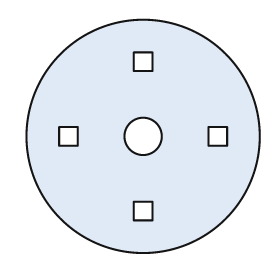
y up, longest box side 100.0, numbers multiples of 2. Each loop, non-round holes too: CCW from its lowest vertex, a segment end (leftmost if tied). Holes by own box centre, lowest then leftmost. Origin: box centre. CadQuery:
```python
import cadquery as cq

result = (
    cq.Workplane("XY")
    .moveTo(0.0, 0.0)
    .circle(50.0)
    .moveTo(-4.0, -36.0)
    .lineTo(4.0, -36.0)
    .lineTo(4.0, -28.0)
    .lineTo(-4.0, -28.0)
    .close()
    .moveTo(-36.0, -4.0)
    .lineTo(-28.0, -4.0)
    .lineTo(-28.0, 4.0)
    .lineTo(-36.0, 4.0)
    .close()
    .moveTo(0.0, 0.0)
    .circle(8.0)
    .moveTo(28.0, -4.0)
    .lineTo(36.0, -4.0)
    .lineTo(36.0, 4.0)
    .lineTo(28.0, 4.0)
    .close()
    .moveTo(-4.0, 28.0)
    .lineTo(4.0, 28.0)
    .lineTo(4.0, 36.0)
    .lineTo(-4.0, 36.0)
    .close()
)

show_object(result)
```